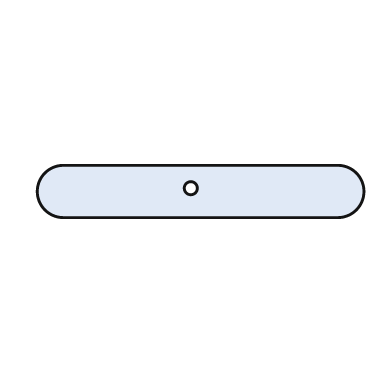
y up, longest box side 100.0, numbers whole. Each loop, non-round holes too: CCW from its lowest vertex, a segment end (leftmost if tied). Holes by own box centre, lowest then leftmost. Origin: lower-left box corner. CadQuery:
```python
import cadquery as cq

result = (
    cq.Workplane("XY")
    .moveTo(8.0, 0.0)
    .lineTo(92.0, 0.0)
    .threePointArc((100.0, 8.0), (92.0, 16.0))
    .lineTo(8.0, 16.0)
    .threePointArc((0.0, 8.0), (8.0, 0.0))
    .close()
    .moveTo(47.0, 9.0)
    .circle(2.0)
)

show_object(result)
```